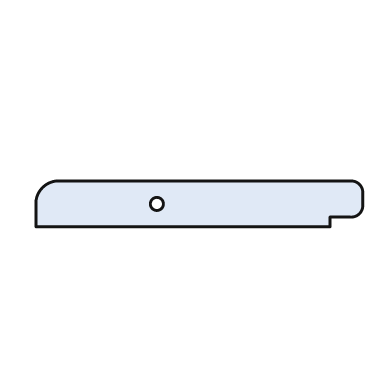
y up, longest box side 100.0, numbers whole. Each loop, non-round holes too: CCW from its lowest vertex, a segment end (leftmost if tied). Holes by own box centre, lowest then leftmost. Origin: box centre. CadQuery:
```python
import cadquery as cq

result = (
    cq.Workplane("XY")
    .moveTo(-50.0, -7.0)
    .lineTo(40.0, -7.0)
    .lineTo(40.0, -4.0)
    .lineTo(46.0, -4.0)
    .threePointArc((49.0, -3.0), (50.0, 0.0))
    .lineTo(50.0, 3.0)
    .threePointArc((49.0, 6.0), (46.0, 7.0))
    .lineTo(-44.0, 7.0)
    .threePointArc((-48.0, 5.0), (-50.0, 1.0))
    .close()
    .moveTo(-13.0, 0.0)
    .circle(2.0)
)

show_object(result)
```